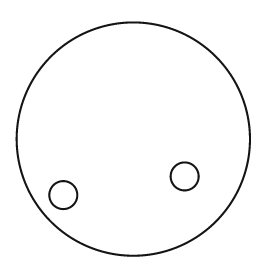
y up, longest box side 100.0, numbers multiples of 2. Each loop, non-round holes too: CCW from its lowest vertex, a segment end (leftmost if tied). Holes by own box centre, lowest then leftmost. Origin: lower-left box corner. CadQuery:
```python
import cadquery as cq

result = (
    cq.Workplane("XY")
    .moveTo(50.0, 50.0)
    .circle(50.0)
    .moveTo(20.0, 26.0)
    .circle(6.0)
    .moveTo(72.0, 34.0)
    .circle(6.0)
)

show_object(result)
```